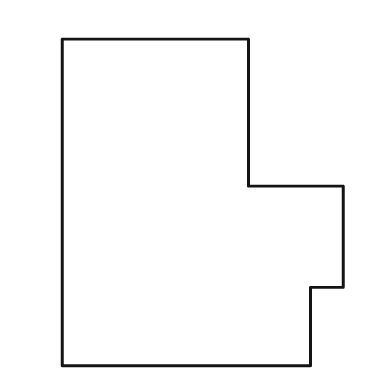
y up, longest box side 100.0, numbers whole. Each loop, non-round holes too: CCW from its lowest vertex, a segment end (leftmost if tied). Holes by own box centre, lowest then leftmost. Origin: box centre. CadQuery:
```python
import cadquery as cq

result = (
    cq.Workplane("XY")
    .moveTo(-43.0, -50.0)
    .lineTo(33.0, -50.0)
    .lineTo(33.0, -26.0)
    .lineTo(43.0, -26.0)
    .lineTo(43.0, 5.0)
    .lineTo(14.0, 5.0)
    .lineTo(14.0, 50.0)
    .lineTo(-43.0, 50.0)
    .close()
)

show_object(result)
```